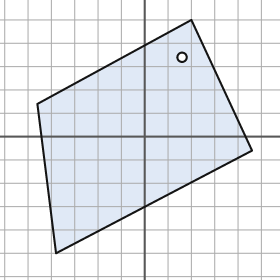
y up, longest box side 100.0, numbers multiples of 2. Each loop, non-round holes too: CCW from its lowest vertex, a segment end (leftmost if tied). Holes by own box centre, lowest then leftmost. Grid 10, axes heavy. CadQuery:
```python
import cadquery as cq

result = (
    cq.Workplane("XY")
    .moveTo(-38.0, -50.0)
    .lineTo(46.0, -6.0)
    .lineTo(20.0, 50.0)
    .lineTo(-46.0, 14.0)
    .close()
    .moveTo(16.0, 34.0)
    .circle(2.0)
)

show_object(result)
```